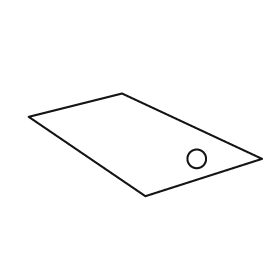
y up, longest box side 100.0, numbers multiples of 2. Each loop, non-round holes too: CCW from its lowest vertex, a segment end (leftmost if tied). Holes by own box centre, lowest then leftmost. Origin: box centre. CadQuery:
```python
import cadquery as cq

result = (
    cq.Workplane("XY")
    .moveTo(0.0, -22.0)
    .lineTo(50.0, -6.0)
    .lineTo(-10.0, 22.0)
    .lineTo(-50.0, 12.0)
    .close()
    .moveTo(22.0, -6.0)
    .circle(4.0)
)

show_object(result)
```